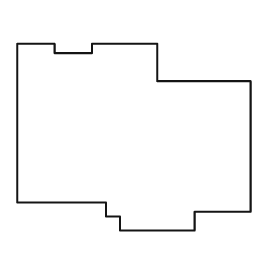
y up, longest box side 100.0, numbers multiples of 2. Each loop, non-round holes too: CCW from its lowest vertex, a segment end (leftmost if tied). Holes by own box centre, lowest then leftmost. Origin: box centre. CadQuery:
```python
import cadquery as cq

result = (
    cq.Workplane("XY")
    .moveTo(-6.0, -40.0)
    .lineTo(26.0, -40.0)
    .lineTo(26.0, -32.0)
    .lineTo(50.0, -32.0)
    .lineTo(50.0, 24.0)
    .lineTo(10.0, 24.0)
    .lineTo(10.0, 40.0)
    .lineTo(-18.0, 40.0)
    .lineTo(-18.0, 36.0)
    .lineTo(-34.0, 36.0)
    .lineTo(-34.0, 40.0)
    .lineTo(-50.0, 40.0)
    .lineTo(-50.0, -28.0)
    .lineTo(-12.0, -28.0)
    .lineTo(-12.0, -34.0)
    .lineTo(-6.0, -34.0)
    .close()
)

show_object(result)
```